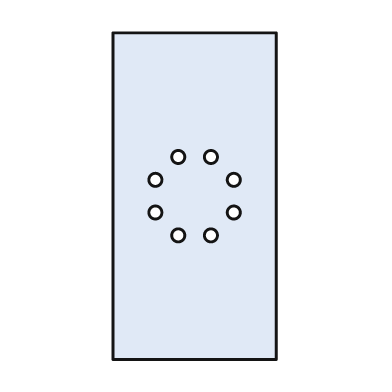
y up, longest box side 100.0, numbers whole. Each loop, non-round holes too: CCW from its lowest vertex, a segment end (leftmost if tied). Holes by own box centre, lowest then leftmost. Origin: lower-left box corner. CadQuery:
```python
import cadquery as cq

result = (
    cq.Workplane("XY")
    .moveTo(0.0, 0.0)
    .lineTo(50.0, 0.0)
    .lineTo(50.0, 100.0)
    .lineTo(0.0, 100.0)
    .close()
    .moveTo(20.0, 38.0)
    .circle(2.0)
    .moveTo(30.0, 38.0)
    .circle(2.0)
    .moveTo(13.0, 45.0)
    .circle(2.0)
    .moveTo(37.0, 45.0)
    .circle(2.0)
    .moveTo(13.0, 55.0)
    .circle(2.0)
    .moveTo(37.0, 55.0)
    .circle(2.0)
    .moveTo(20.0, 62.0)
    .circle(2.0)
    .moveTo(30.0, 62.0)
    .circle(2.0)
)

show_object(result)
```